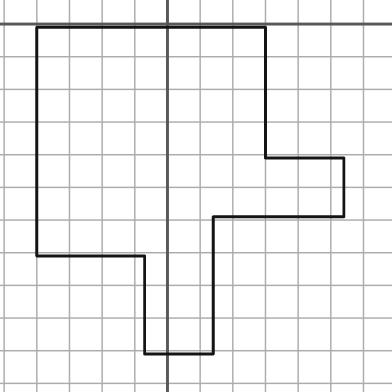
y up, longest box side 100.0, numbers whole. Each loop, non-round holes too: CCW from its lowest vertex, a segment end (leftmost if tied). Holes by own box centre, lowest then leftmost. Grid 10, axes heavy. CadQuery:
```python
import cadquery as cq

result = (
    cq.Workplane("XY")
    .moveTo(-7.0, -101.0)
    .lineTo(14.0, -101.0)
    .lineTo(14.0, -59.0)
    .lineTo(54.0, -59.0)
    .lineTo(54.0, -41.0)
    .lineTo(30.0, -41.0)
    .lineTo(30.0, -1.0)
    .lineTo(-40.0, -1.0)
    .lineTo(-40.0, -71.0)
    .lineTo(-7.0, -71.0)
    .close()
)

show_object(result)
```